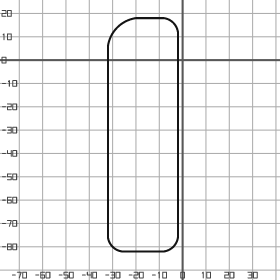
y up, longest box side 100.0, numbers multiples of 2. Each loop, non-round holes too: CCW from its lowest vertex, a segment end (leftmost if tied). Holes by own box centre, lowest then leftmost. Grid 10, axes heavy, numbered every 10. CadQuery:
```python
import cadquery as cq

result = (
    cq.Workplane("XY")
    .moveTo(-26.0, -82.0)
    .lineTo(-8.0, -82.0)
    .threePointArc((-4.0, -80.0), (-2.0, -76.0))
    .lineTo(-2.0, 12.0)
    .threePointArc((-4.0, 16.0), (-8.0, 18.0))
    .lineTo(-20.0, 18.0)
    .threePointArc((-28.0, 14.0), (-32.0, 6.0))
    .lineTo(-32.0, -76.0)
    .threePointArc((-30.0, -80.0), (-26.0, -82.0))
    .close()
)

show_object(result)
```